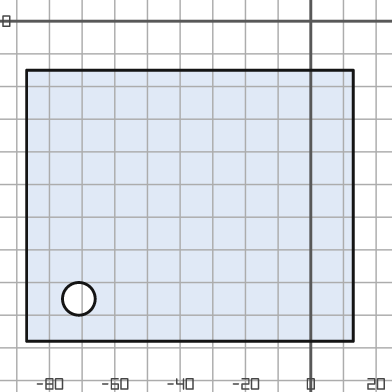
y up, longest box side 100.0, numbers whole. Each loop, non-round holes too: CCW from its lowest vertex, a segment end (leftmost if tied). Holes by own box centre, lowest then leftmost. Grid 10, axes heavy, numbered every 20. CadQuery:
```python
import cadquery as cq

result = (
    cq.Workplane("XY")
    .moveTo(-87.0, -98.0)
    .lineTo(13.0, -98.0)
    .lineTo(13.0, -15.0)
    .lineTo(-87.0, -15.0)
    .close()
    .moveTo(-71.0, -85.0)
    .circle(5.0)
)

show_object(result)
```